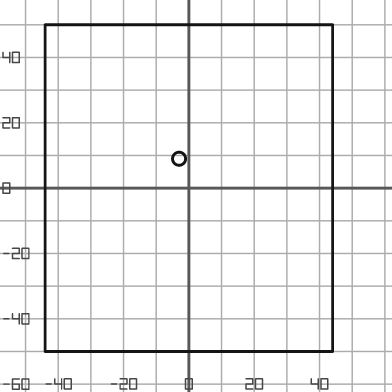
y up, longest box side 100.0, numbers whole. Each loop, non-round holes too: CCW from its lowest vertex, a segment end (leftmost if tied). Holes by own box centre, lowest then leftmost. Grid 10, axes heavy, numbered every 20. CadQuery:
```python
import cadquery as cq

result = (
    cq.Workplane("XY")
    .moveTo(-44.0, -50.0)
    .lineTo(44.0, -50.0)
    .lineTo(44.0, 50.0)
    .lineTo(-44.0, 50.0)
    .close()
    .moveTo(-3.0, 9.0)
    .circle(2.0)
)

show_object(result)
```